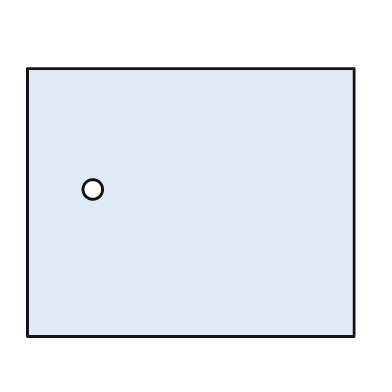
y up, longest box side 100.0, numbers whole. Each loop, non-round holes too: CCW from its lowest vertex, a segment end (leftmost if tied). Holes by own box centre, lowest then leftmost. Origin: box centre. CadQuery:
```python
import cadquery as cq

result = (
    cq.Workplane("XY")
    .moveTo(-50.0, -41.0)
    .lineTo(50.0, -41.0)
    .lineTo(50.0, 41.0)
    .lineTo(-50.0, 41.0)
    .close()
    .moveTo(-30.0, 4.0)
    .circle(3.0)
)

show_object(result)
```